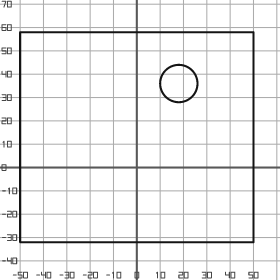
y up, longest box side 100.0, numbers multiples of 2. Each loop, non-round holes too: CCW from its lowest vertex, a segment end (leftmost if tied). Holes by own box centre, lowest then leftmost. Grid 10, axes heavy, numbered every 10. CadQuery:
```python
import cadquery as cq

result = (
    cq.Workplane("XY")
    .moveTo(-50.0, -32.0)
    .lineTo(50.0, -32.0)
    .lineTo(50.0, 58.0)
    .lineTo(-50.0, 58.0)
    .close()
    .moveTo(18.0, 36.0)
    .circle(8.0)
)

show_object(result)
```